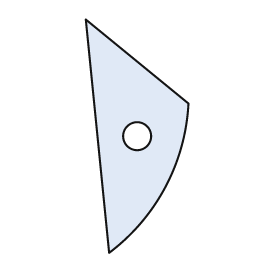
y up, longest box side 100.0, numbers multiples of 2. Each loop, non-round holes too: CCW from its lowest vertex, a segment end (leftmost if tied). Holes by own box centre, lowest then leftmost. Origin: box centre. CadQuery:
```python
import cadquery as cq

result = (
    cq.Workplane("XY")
    .moveTo(-12.0, -50.0)
    .threePointArc((12.0, -22.0), (22.0, 14.0))
    .lineTo(-22.0, 50.0)
    .close()
    .moveTo(0.0, 0.0)
    .circle(6.0)
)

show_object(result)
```